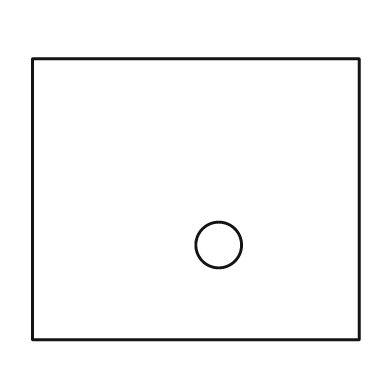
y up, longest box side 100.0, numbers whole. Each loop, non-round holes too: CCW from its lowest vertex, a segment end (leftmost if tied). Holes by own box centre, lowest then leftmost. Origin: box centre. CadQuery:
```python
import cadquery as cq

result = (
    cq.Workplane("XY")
    .moveTo(-50.0, -43.0)
    .lineTo(50.0, -43.0)
    .lineTo(50.0, 43.0)
    .lineTo(-50.0, 43.0)
    .close()
    .moveTo(7.0, -14.0)
    .circle(7.0)
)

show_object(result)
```